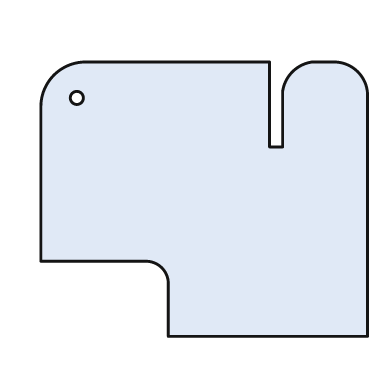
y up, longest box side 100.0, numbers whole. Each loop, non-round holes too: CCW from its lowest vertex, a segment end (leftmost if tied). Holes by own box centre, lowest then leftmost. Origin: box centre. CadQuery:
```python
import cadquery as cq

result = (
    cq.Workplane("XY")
    .moveTo(-11.0, -42.0)
    .lineTo(50.0, -42.0)
    .lineTo(50.0, 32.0)
    .threePointArc((47.0, 39.0), (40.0, 42.0))
    .lineTo(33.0, 42.0)
    .threePointArc((27.0, 39.0), (24.0, 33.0))
    .lineTo(24.0, 16.0)
    .lineTo(20.0, 16.0)
    .lineTo(20.0, 42.0)
    .lineTo(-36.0, 42.0)
    .threePointArc((-46.0, 38.0), (-50.0, 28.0))
    .lineTo(-50.0, -19.0)
    .lineTo(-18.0, -19.0)
    .threePointArc((-13.0, -21.0), (-11.0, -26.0))
    .close()
    .moveTo(-39.0, 31.0)
    .circle(2.0)
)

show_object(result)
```